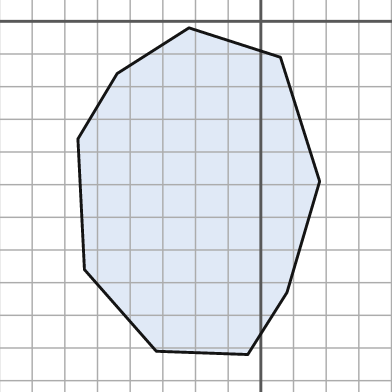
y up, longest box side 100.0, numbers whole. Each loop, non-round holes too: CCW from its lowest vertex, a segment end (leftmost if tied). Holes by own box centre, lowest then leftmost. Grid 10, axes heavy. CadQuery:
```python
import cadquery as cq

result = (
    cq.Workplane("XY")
    .moveTo(-4.0, -102.0)
    .lineTo(8.0, -83.0)
    .lineTo(18.0, -49.0)
    .lineTo(6.0, -11.0)
    .lineTo(-22.0, -2.0)
    .lineTo(-44.0, -16.0)
    .lineTo(-56.0, -36.0)
    .lineTo(-54.0, -76.0)
    .lineTo(-32.0, -101.0)
    .close()
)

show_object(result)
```